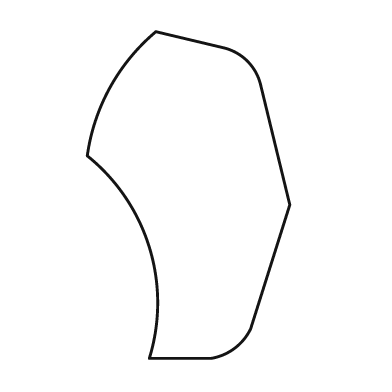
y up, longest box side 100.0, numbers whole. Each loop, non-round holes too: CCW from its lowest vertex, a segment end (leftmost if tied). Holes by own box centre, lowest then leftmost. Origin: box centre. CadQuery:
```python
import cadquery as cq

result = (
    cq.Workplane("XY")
    .moveTo(-12.0, -50.0)
    .lineTo(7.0, -50.0)
    .threePointArc((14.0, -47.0), (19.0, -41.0))
    .lineTo(31.0, -3.0)
    .lineTo(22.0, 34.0)
    .threePointArc((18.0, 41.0), (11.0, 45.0))
    .lineTo(-10.0, 50.0)
    .threePointArc((-24.0, 33.0), (-31.0, 12.0))
    .threePointArc((-12.0, -16.0), (-12.0, -50.0))
    .close()
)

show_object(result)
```